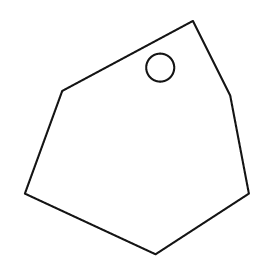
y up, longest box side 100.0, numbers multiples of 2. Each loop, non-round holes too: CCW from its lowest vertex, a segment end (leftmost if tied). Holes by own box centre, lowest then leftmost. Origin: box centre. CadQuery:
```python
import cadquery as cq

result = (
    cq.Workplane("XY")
    .moveTo(8.0, -50.0)
    .lineTo(48.0, -24.0)
    .lineTo(40.0, 18.0)
    .lineTo(24.0, 50.0)
    .lineTo(-32.0, 20.0)
    .lineTo(-48.0, -24.0)
    .close()
    .moveTo(10.0, 30.0)
    .circle(6.0)
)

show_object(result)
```